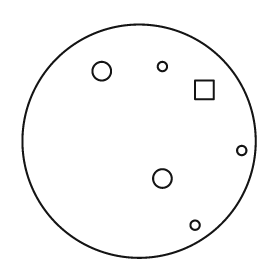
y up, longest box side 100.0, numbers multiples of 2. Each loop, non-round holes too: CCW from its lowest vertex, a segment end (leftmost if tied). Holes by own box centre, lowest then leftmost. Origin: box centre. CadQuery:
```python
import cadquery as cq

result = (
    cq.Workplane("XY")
    .moveTo(0.0, 0.0)
    .circle(50.0)
    .moveTo(24.0, -36.0)
    .circle(2.0)
    .moveTo(10.0, -16.0)
    .circle(4.0)
    .moveTo(44.0, -4.0)
    .circle(2.0)
    .moveTo(24.0, 18.0)
    .lineTo(32.0, 18.0)
    .lineTo(32.0, 26.0)
    .lineTo(24.0, 26.0)
    .close()
    .moveTo(-16.0, 30.0)
    .circle(4.0)
    .moveTo(10.0, 32.0)
    .circle(2.0)
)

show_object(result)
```